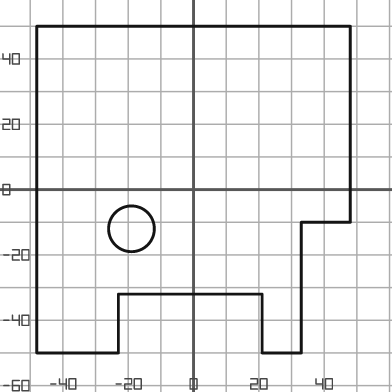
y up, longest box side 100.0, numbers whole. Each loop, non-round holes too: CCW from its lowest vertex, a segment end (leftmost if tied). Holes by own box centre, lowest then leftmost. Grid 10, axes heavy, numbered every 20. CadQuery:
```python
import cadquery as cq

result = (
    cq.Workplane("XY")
    .moveTo(-48.0, -50.0)
    .lineTo(-23.0, -50.0)
    .lineTo(-23.0, -32.0)
    .lineTo(21.0, -32.0)
    .lineTo(21.0, -50.0)
    .lineTo(33.0, -50.0)
    .lineTo(33.0, -10.0)
    .lineTo(48.0, -10.0)
    .lineTo(48.0, 50.0)
    .lineTo(-48.0, 50.0)
    .close()
    .moveTo(-19.0, -12.0)
    .circle(7.0)
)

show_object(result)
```